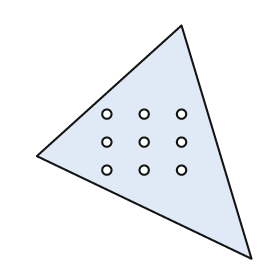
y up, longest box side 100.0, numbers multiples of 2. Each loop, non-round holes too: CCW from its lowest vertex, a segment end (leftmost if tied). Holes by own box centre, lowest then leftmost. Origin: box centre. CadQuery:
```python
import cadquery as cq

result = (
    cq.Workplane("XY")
    .moveTo(46.0, -50.0)
    .lineTo(16.0, 50.0)
    .lineTo(-46.0, -6.0)
    .close()
    .moveTo(-16.0, -12.0)
    .circle(2.0)
    .moveTo(0.0, -12.0)
    .circle(2.0)
    .moveTo(16.0, -12.0)
    .circle(2.0)
    .moveTo(-16.0, 0.0)
    .circle(2.0)
    .moveTo(0.0, 0.0)
    .circle(2.0)
    .moveTo(16.0, 0.0)
    .circle(2.0)
    .moveTo(-16.0, 12.0)
    .circle(2.0)
    .moveTo(0.0, 12.0)
    .circle(2.0)
    .moveTo(16.0, 12.0)
    .circle(2.0)
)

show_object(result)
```